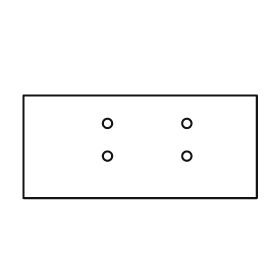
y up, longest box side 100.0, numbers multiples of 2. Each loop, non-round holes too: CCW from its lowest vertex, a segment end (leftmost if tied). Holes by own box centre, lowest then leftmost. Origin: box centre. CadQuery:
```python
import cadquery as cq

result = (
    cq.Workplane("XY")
    .moveTo(-50.0, -22.0)
    .lineTo(50.0, -22.0)
    .lineTo(50.0, 22.0)
    .lineTo(-50.0, 22.0)
    .close()
    .moveTo(-14.0, -4.0)
    .circle(2.0)
    .moveTo(20.0, -4.0)
    .circle(2.0)
    .moveTo(-14.0, 10.0)
    .circle(2.0)
    .moveTo(20.0, 10.0)
    .circle(2.0)
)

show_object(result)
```